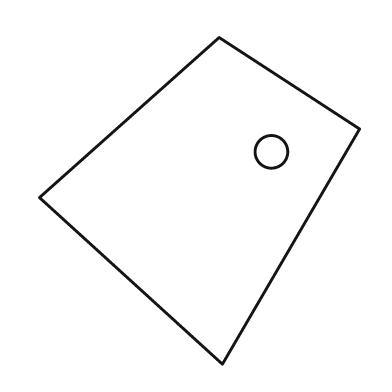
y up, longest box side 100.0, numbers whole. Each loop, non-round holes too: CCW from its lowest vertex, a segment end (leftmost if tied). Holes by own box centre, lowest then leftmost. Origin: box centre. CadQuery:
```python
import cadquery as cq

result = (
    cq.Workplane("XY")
    .moveTo(7.0, -50.0)
    .lineTo(49.0, 22.0)
    .lineTo(6.0, 50.0)
    .lineTo(-49.0, 1.0)
    .close()
    .moveTo(22.0, 15.0)
    .circle(5.0)
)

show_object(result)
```